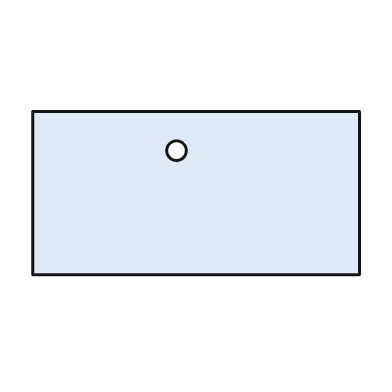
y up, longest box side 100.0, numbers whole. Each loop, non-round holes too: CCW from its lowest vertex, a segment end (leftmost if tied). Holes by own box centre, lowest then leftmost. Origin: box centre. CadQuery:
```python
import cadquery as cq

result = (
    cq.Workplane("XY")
    .moveTo(-50.0, -25.0)
    .lineTo(50.0, -25.0)
    .lineTo(50.0, 25.0)
    .lineTo(-50.0, 25.0)
    .close()
    .moveTo(-6.0, 13.0)
    .circle(3.0)
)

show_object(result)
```